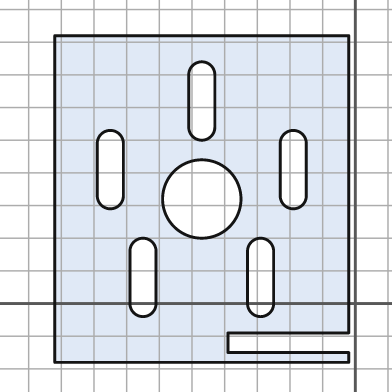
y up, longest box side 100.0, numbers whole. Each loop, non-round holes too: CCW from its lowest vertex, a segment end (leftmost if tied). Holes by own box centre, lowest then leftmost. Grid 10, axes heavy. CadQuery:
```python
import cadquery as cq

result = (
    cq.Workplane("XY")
    .moveTo(-92.0, -18.0)
    .lineTo(-2.0, -18.0)
    .lineTo(-2.0, -15.0)
    .lineTo(-39.0, -15.0)
    .lineTo(-39.0, -9.0)
    .lineTo(-2.0, -9.0)
    .lineTo(-2.0, 82.0)
    .lineTo(-92.0, 82.0)
    .close()
    .moveTo(-69.0, 0.0)
    .threePointArc((-65.0, -4.0), (-61.0, 0.0))
    .lineTo(-61.0, 16.0)
    .threePointArc((-65.0, 20.0), (-69.0, 16.0))
    .close()
    .moveTo(-33.0, 0.0)
    .threePointArc((-29.0, -4.0), (-25.0, 0.0))
    .lineTo(-25.0, 16.0)
    .threePointArc((-29.0, 20.0), (-33.0, 16.0))
    .close()
    .moveTo(-47.0, 32.0)
    .circle(12.0)
    .moveTo(-79.0, 33.0)
    .threePointArc((-75.0, 29.0), (-71.0, 33.0))
    .lineTo(-71.0, 49.0)
    .threePointArc((-75.0, 53.0), (-79.0, 49.0))
    .close()
    .moveTo(-23.0, 33.0)
    .threePointArc((-19.0, 29.0), (-15.0, 33.0))
    .lineTo(-15.0, 49.0)
    .threePointArc((-19.0, 53.0), (-23.0, 49.0))
    .close()
    .moveTo(-51.0, 54.0)
    .threePointArc((-47.0, 50.0), (-43.0, 54.0))
    .lineTo(-43.0, 70.0)
    .threePointArc((-47.0, 74.0), (-51.0, 70.0))
    .close()
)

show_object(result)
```